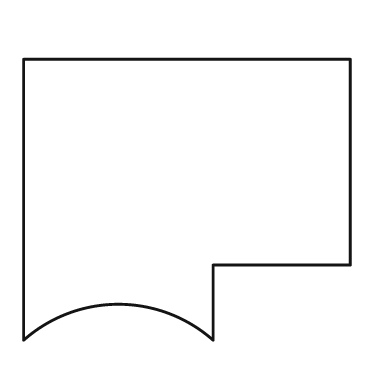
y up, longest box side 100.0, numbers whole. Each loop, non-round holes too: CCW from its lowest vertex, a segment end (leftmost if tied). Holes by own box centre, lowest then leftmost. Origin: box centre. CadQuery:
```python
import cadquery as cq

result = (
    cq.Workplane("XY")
    .moveTo(-50.0, -43.0)
    .threePointArc((-21.0, -32.0), (8.0, -43.0))
    .lineTo(8.0, -20.0)
    .lineTo(50.0, -20.0)
    .lineTo(50.0, 43.0)
    .lineTo(-50.0, 43.0)
    .close()
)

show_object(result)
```